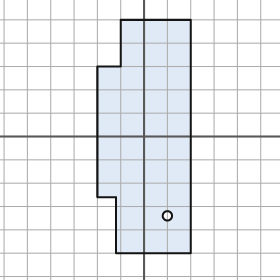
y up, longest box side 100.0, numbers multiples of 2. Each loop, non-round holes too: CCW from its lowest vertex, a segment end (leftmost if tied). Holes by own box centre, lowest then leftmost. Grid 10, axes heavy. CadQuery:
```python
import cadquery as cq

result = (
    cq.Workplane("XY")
    .moveTo(-12.0, -50.0)
    .lineTo(20.0, -50.0)
    .lineTo(20.0, 50.0)
    .lineTo(-10.0, 50.0)
    .lineTo(-10.0, 30.0)
    .lineTo(-20.0, 30.0)
    .lineTo(-20.0, -26.0)
    .lineTo(-12.0, -26.0)
    .close()
    .moveTo(10.0, -34.0)
    .circle(2.0)
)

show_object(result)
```